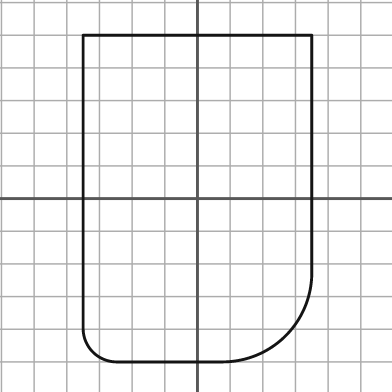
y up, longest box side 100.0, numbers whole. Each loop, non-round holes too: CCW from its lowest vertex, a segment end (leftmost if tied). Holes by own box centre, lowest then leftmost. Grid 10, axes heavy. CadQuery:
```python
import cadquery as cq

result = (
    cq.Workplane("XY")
    .moveTo(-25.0, -50.0)
    .lineTo(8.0, -50.0)
    .threePointArc((27.0, -42.0), (35.0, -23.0))
    .lineTo(35.0, 50.0)
    .lineTo(-35.0, 50.0)
    .lineTo(-35.0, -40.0)
    .threePointArc((-32.0, -47.0), (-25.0, -50.0))
    .close()
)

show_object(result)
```